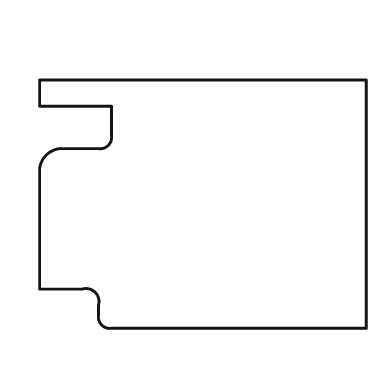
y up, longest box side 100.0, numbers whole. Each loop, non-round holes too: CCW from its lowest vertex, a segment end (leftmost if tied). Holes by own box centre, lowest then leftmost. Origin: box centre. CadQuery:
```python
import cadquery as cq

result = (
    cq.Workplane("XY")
    .moveTo(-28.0, -38.0)
    .lineTo(50.0, -38.0)
    .lineTo(50.0, 38.0)
    .lineTo(-50.0, 38.0)
    .lineTo(-50.0, 30.0)
    .lineTo(-28.0, 30.0)
    .lineTo(-28.0, 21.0)
    .threePointArc((-29.0, 18.0), (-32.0, 17.0))
    .lineTo(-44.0, 17.0)
    .threePointArc((-48.0, 15.0), (-50.0, 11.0))
    .lineTo(-50.0, -26.0)
    .lineTo(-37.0, -26.0)
    .threePointArc((-33.0, -27.0), (-32.0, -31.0))
    .lineTo(-32.0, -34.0)
    .threePointArc((-31.0, -37.0), (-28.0, -38.0))
    .close()
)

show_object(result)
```